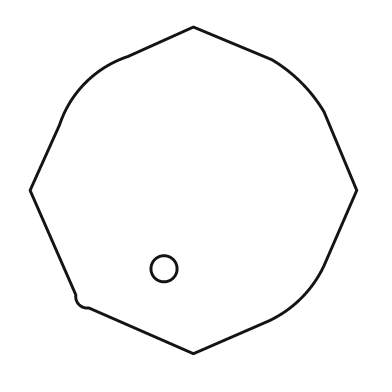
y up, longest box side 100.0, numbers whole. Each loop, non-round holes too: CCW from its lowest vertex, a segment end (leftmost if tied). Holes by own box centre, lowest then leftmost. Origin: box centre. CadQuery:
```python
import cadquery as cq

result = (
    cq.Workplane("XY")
    .moveTo(0.0, -50.0)
    .lineTo(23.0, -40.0)
    .threePointArc((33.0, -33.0), (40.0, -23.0))
    .lineTo(50.0, 0.0)
    .lineTo(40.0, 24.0)
    .threePointArc((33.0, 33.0), (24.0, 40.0))
    .lineTo(0.0, 50.0)
    .lineTo(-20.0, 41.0)
    .threePointArc((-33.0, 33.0), (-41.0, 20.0))
    .lineTo(-50.0, 0.0)
    .lineTo(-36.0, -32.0)
    .threePointArc((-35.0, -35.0), (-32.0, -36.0))
    .close()
    .moveTo(-9.0, -24.0)
    .circle(4.0)
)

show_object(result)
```